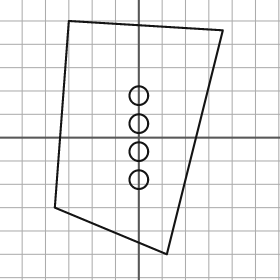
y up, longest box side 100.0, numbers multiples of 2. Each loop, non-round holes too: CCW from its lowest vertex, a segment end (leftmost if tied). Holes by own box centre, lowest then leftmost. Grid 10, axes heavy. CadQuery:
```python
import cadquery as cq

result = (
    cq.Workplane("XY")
    .moveTo(12.0, -50.0)
    .lineTo(36.0, 46.0)
    .lineTo(-30.0, 50.0)
    .lineTo(-36.0, -30.0)
    .close()
    .moveTo(0.0, -18.0)
    .circle(4.0)
    .moveTo(0.0, -6.0)
    .circle(4.0)
    .moveTo(0.0, 6.0)
    .circle(4.0)
    .moveTo(0.0, 18.0)
    .circle(4.0)
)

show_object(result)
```